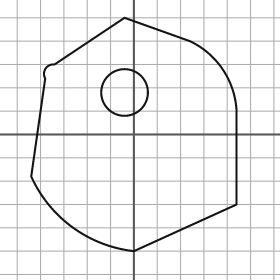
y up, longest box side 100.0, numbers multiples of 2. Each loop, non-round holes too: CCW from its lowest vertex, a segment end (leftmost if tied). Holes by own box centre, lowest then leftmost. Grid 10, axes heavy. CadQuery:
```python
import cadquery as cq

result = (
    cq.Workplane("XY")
    .moveTo(0.0, -50.0)
    .lineTo(44.0, -30.0)
    .lineTo(44.0, 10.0)
    .threePointArc((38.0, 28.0), (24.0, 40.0))
    .lineTo(-4.0, 50.0)
    .lineTo(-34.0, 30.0)
    .threePointArc((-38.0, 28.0), (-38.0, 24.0))
    .lineTo(-44.0, -18.0)
    .threePointArc((-26.0, -40.0), (0.0, -50.0))
    .close()
    .moveTo(-4.0, 18.0)
    .circle(10.0)
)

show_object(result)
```